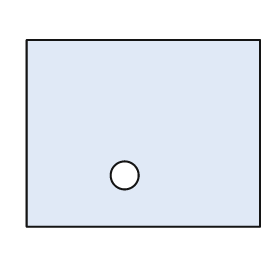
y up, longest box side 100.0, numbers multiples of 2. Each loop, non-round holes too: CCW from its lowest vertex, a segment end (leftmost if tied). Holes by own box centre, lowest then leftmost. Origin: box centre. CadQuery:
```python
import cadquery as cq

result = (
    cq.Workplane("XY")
    .moveTo(-50.0, -40.0)
    .lineTo(50.0, -40.0)
    .lineTo(50.0, 40.0)
    .lineTo(-50.0, 40.0)
    .close()
    .moveTo(-8.0, -18.0)
    .circle(6.0)
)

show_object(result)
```